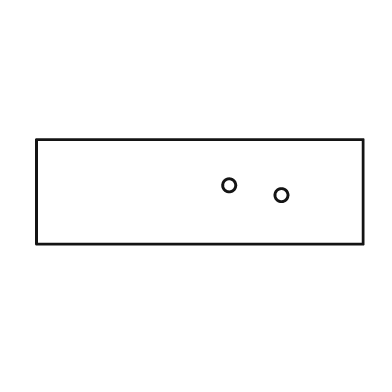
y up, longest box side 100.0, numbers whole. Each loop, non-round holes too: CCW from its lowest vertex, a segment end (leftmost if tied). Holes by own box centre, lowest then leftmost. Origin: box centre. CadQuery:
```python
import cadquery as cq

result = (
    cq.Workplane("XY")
    .moveTo(-50.0, -16.0)
    .lineTo(50.0, -16.0)
    .lineTo(50.0, 16.0)
    .lineTo(-50.0, 16.0)
    .close()
    .moveTo(25.0, -1.0)
    .circle(2.0)
    .moveTo(9.0, 2.0)
    .circle(2.0)
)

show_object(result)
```